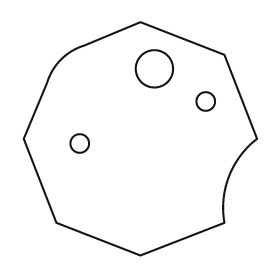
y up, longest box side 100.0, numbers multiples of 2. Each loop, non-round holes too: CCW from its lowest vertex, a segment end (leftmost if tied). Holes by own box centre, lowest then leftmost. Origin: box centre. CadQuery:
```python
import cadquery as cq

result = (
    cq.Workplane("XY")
    .moveTo(0.0, -50.0)
    .lineTo(36.0, -36.0)
    .threePointArc((38.0, -16.0), (50.0, 0.0))
    .lineTo(36.0, 36.0)
    .lineTo(0.0, 50.0)
    .lineTo(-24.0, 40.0)
    .threePointArc((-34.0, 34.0), (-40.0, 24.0))
    .lineTo(-50.0, 0.0)
    .lineTo(-36.0, -36.0)
    .close()
    .moveTo(-26.0, -2.0)
    .circle(4.0)
    .moveTo(28.0, 16.0)
    .circle(4.0)
    .moveTo(6.0, 30.0)
    .circle(8.0)
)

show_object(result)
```